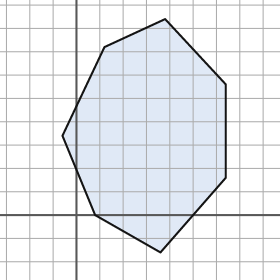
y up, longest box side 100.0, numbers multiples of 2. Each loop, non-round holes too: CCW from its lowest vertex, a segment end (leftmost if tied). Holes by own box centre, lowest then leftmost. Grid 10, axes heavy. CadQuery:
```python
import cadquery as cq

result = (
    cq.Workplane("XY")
    .moveTo(36.0, -16.0)
    .lineTo(64.0, 16.0)
    .lineTo(64.0, 56.0)
    .lineTo(38.0, 84.0)
    .lineTo(12.0, 72.0)
    .lineTo(-6.0, 34.0)
    .lineTo(8.0, 0.0)
    .close()
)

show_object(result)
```